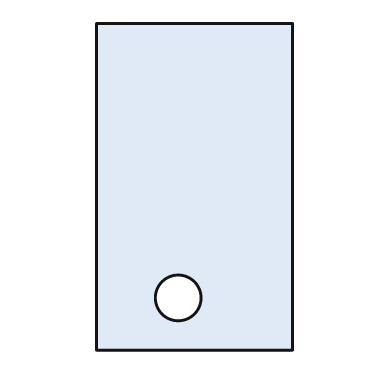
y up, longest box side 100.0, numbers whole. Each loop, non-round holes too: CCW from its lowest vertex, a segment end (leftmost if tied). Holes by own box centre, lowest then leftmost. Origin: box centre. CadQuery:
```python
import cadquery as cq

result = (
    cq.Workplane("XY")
    .moveTo(-30.0, -50.0)
    .lineTo(30.0, -50.0)
    .lineTo(30.0, 50.0)
    .lineTo(-30.0, 50.0)
    .close()
    .moveTo(-5.0, -34.0)
    .circle(7.0)
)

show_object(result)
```